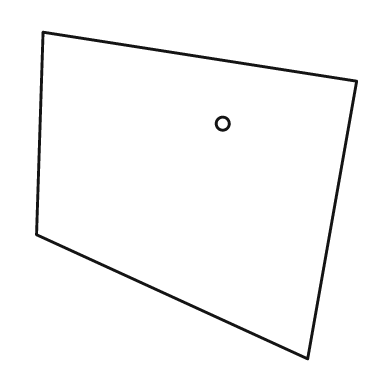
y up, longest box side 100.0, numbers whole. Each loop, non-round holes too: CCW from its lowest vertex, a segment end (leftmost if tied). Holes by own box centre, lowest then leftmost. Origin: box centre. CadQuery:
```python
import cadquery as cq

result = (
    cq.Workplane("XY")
    .moveTo(34.0, -50.0)
    .lineTo(49.0, 35.0)
    .lineTo(-47.0, 50.0)
    .lineTo(-49.0, -12.0)
    .close()
    .moveTo(8.0, 22.0)
    .circle(2.0)
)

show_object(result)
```